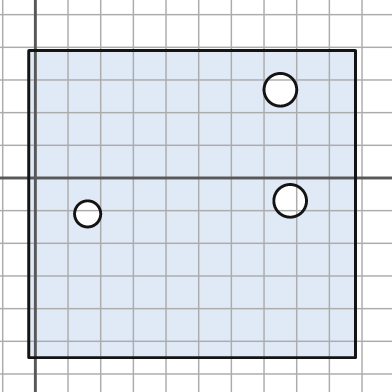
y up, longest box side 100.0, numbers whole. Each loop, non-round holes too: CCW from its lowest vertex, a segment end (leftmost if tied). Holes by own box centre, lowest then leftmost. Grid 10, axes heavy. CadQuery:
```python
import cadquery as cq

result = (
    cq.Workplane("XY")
    .moveTo(-2.0, -55.0)
    .lineTo(98.0, -55.0)
    .lineTo(98.0, 39.0)
    .lineTo(-2.0, 39.0)
    .close()
    .moveTo(16.0, -11.0)
    .circle(4.0)
    .moveTo(78.0, -7.0)
    .circle(5.0)
    .moveTo(75.0, 27.0)
    .circle(5.0)
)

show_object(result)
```